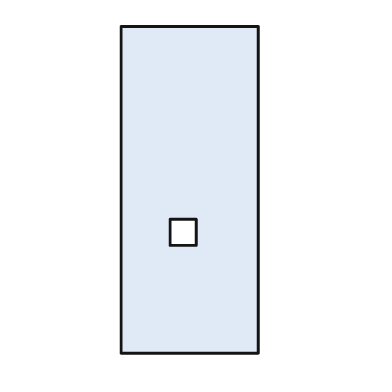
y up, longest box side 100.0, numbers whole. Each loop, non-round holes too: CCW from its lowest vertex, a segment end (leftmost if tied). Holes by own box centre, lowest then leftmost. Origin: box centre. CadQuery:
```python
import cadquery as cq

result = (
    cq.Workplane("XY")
    .moveTo(-21.0, -50.0)
    .lineTo(21.0, -50.0)
    .lineTo(21.0, 50.0)
    .lineTo(-21.0, 50.0)
    .close()
    .moveTo(-6.0, -17.0)
    .lineTo(2.0, -17.0)
    .lineTo(2.0, -9.0)
    .lineTo(-6.0, -9.0)
    .close()
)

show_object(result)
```